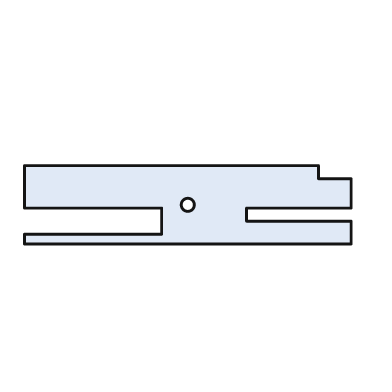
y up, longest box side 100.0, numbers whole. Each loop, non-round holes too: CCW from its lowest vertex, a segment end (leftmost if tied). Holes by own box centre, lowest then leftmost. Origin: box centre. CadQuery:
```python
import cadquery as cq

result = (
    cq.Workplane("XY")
    .moveTo(-50.0, -12.0)
    .lineTo(50.0, -12.0)
    .lineTo(50.0, -5.0)
    .lineTo(18.0, -5.0)
    .lineTo(18.0, -1.0)
    .lineTo(50.0, -1.0)
    .lineTo(50.0, 8.0)
    .lineTo(40.0, 8.0)
    .lineTo(40.0, 12.0)
    .lineTo(-50.0, 12.0)
    .lineTo(-50.0, -1.0)
    .lineTo(-8.0, -1.0)
    .lineTo(-8.0, -9.0)
    .lineTo(-50.0, -9.0)
    .close()
    .moveTo(0.0, 0.0)
    .circle(2.0)
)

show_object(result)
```